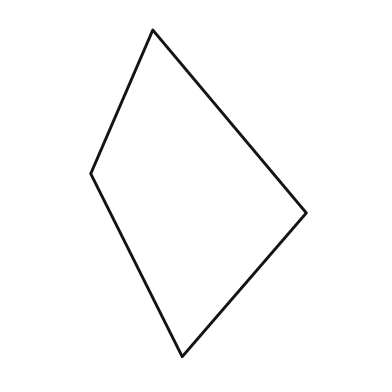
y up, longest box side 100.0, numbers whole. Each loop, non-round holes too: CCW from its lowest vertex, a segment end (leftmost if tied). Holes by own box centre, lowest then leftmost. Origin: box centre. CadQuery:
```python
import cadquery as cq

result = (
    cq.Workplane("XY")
    .moveTo(-5.0, -50.0)
    .lineTo(33.0, -6.0)
    .lineTo(-14.0, 50.0)
    .lineTo(-33.0, 6.0)
    .close()
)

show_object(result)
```